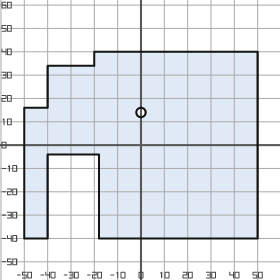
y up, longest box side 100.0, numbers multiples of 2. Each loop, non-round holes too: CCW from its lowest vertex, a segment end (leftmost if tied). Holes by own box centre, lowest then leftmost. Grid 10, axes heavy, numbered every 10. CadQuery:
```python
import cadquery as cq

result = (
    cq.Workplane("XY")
    .moveTo(-50.0, -40.0)
    .lineTo(-40.0, -40.0)
    .lineTo(-40.0, -4.0)
    .lineTo(-18.0, -4.0)
    .lineTo(-18.0, -40.0)
    .lineTo(50.0, -40.0)
    .lineTo(50.0, 40.0)
    .lineTo(-20.0, 40.0)
    .lineTo(-20.0, 34.0)
    .lineTo(-40.0, 34.0)
    .lineTo(-40.0, 16.0)
    .lineTo(-50.0, 16.0)
    .close()
    .moveTo(0.0, 14.0)
    .circle(2.0)
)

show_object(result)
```